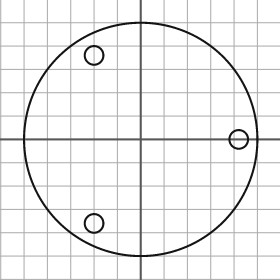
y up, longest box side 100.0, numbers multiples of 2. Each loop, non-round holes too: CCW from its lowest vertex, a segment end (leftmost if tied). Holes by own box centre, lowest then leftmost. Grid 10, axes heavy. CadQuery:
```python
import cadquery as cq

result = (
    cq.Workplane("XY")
    .moveTo(0.0, 0.0)
    .circle(50.0)
    .moveTo(-20.0, -36.0)
    .circle(4.0)
    .moveTo(42.0, 0.0)
    .circle(4.0)
    .moveTo(-20.0, 36.0)
    .circle(4.0)
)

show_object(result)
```